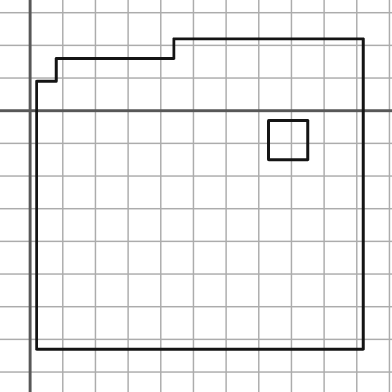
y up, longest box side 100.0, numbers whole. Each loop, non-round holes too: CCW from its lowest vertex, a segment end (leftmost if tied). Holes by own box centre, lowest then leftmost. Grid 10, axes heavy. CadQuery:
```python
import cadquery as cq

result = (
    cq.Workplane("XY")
    .moveTo(2.0, -73.0)
    .lineTo(102.0, -73.0)
    .lineTo(102.0, 22.0)
    .lineTo(44.0, 22.0)
    .lineTo(44.0, 16.0)
    .lineTo(8.0, 16.0)
    .lineTo(8.0, 9.0)
    .lineTo(2.0, 9.0)
    .close()
    .moveTo(73.0, -15.0)
    .lineTo(85.0, -15.0)
    .lineTo(85.0, -3.0)
    .lineTo(73.0, -3.0)
    .close()
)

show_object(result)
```